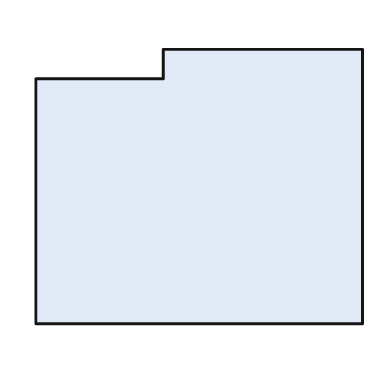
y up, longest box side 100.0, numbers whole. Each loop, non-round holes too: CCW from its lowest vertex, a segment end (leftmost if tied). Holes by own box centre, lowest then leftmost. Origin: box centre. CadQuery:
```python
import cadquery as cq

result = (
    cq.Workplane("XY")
    .moveTo(-50.0, -42.0)
    .lineTo(50.0, -42.0)
    .lineTo(50.0, 42.0)
    .lineTo(-11.0, 42.0)
    .lineTo(-11.0, 33.0)
    .lineTo(-50.0, 33.0)
    .close()
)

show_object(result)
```